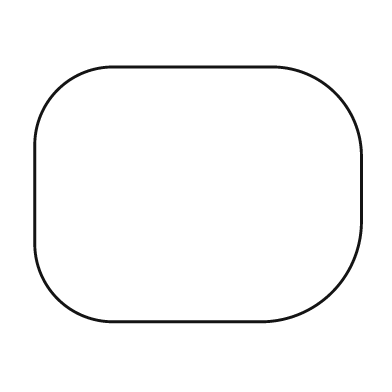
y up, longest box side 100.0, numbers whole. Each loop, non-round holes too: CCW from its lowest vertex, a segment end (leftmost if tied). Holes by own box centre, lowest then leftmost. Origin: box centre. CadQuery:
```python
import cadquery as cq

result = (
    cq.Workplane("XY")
    .moveTo(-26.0, -39.0)
    .lineTo(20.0, -39.0)
    .threePointArc((41.0, -30.0), (50.0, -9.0))
    .lineTo(50.0, 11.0)
    .threePointArc((42.0, 31.0), (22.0, 39.0))
    .lineTo(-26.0, 39.0)
    .threePointArc((-43.0, 32.0), (-50.0, 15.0))
    .lineTo(-50.0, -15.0)
    .threePointArc((-43.0, -32.0), (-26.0, -39.0))
    .close()
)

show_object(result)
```